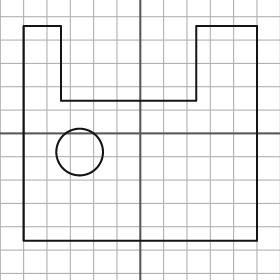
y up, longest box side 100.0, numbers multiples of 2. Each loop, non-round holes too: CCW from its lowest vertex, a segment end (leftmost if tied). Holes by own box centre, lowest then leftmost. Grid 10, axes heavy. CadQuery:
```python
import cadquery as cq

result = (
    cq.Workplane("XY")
    .moveTo(-50.0, -46.0)
    .lineTo(50.0, -46.0)
    .lineTo(50.0, 46.0)
    .lineTo(24.0, 46.0)
    .lineTo(24.0, 14.0)
    .lineTo(-34.0, 14.0)
    .lineTo(-34.0, 46.0)
    .lineTo(-50.0, 46.0)
    .close()
    .moveTo(-26.0, -8.0)
    .circle(10.0)
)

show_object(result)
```